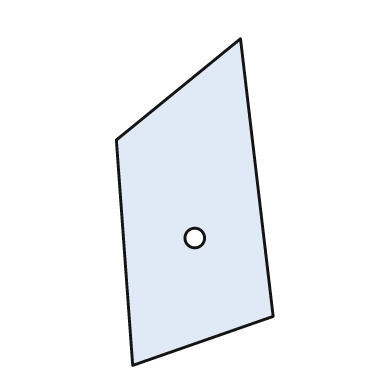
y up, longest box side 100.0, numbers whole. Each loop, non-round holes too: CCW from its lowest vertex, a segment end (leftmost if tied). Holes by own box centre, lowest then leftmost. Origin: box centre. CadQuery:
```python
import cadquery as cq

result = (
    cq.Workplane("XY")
    .moveTo(-19.0, -50.0)
    .lineTo(24.0, -35.0)
    .lineTo(14.0, 50.0)
    .lineTo(-24.0, 19.0)
    .close()
    .moveTo(0.0, -11.0)
    .circle(3.0)
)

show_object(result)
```